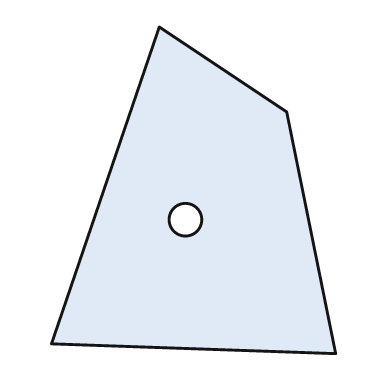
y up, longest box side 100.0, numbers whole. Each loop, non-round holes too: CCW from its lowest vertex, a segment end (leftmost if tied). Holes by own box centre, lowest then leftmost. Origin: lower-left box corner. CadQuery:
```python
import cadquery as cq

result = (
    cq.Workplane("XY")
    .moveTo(87.0, 0.0)
    .lineTo(72.0, 74.0)
    .lineTo(33.0, 100.0)
    .lineTo(0.0, 3.0)
    .close()
    .moveTo(41.0, 41.0)
    .circle(5.0)
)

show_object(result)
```